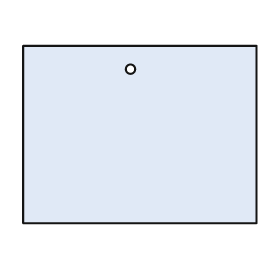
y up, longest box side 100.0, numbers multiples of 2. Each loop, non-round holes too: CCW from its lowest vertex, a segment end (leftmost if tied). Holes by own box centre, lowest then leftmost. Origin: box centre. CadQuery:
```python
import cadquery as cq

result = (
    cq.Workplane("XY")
    .moveTo(-50.0, -38.0)
    .lineTo(50.0, -38.0)
    .lineTo(50.0, 38.0)
    .lineTo(-50.0, 38.0)
    .close()
    .moveTo(-4.0, 28.0)
    .circle(2.0)
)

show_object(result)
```